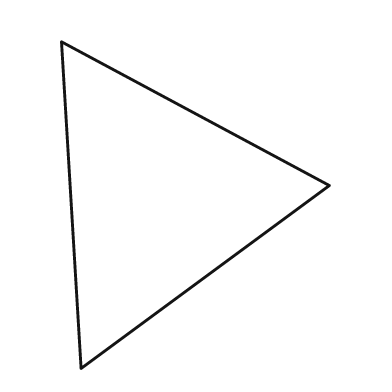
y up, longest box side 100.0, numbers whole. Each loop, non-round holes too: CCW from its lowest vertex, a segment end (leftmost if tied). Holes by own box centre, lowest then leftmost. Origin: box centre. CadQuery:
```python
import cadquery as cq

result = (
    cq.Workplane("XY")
    .moveTo(-35.0, -50.0)
    .lineTo(41.0, 6.0)
    .lineTo(-41.0, 50.0)
    .close()
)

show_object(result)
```